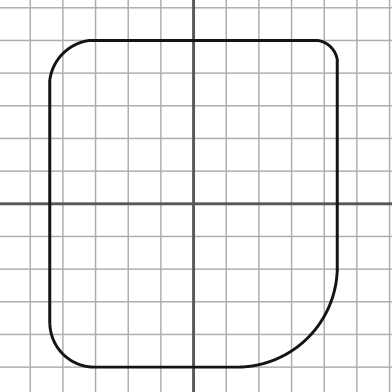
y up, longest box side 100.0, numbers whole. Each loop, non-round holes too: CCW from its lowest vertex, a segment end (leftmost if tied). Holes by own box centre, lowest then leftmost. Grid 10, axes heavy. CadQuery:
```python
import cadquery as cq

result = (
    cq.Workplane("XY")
    .moveTo(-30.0, -50.0)
    .lineTo(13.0, -50.0)
    .threePointArc((35.0, -41.0), (44.0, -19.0))
    .lineTo(44.0, 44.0)
    .threePointArc((42.0, 48.0), (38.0, 50.0))
    .lineTo(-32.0, 50.0)
    .threePointArc((-40.0, 46.0), (-44.0, 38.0))
    .lineTo(-44.0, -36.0)
    .threePointArc((-40.0, -46.0), (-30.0, -50.0))
    .close()
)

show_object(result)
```